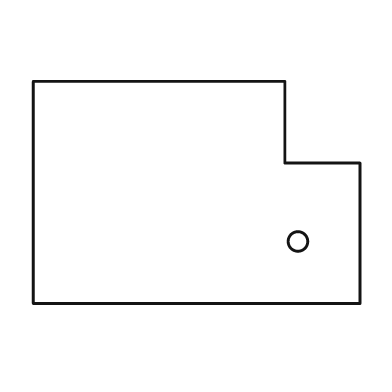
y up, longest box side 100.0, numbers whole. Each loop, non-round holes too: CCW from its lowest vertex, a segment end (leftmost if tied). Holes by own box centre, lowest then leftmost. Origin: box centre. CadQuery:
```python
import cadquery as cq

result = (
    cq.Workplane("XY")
    .moveTo(-50.0, -34.0)
    .lineTo(50.0, -34.0)
    .lineTo(50.0, 9.0)
    .lineTo(27.0, 9.0)
    .lineTo(27.0, 34.0)
    .lineTo(-50.0, 34.0)
    .close()
    .moveTo(31.0, -15.0)
    .circle(3.0)
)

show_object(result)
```